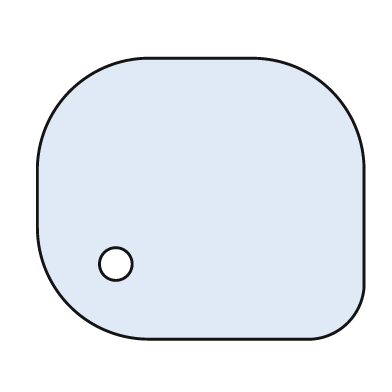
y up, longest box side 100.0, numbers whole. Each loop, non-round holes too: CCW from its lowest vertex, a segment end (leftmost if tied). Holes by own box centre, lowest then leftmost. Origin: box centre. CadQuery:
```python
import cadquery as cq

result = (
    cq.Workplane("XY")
    .moveTo(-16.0, -43.0)
    .lineTo(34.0, -43.0)
    .threePointArc((45.0, -38.0), (50.0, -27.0))
    .lineTo(50.0, 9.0)
    .threePointArc((40.0, 33.0), (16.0, 43.0))
    .lineTo(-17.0, 43.0)
    .threePointArc((-40.0, 33.0), (-50.0, 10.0))
    .lineTo(-50.0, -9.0)
    .threePointArc((-40.0, -33.0), (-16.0, -43.0))
    .close()
    .moveTo(-26.0, -20.0)
    .circle(5.0)
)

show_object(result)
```